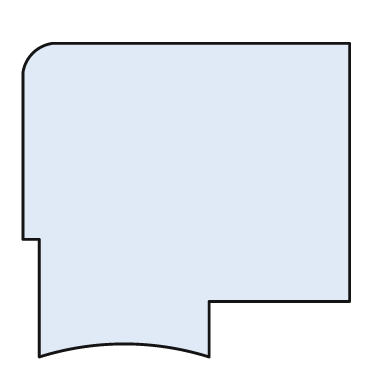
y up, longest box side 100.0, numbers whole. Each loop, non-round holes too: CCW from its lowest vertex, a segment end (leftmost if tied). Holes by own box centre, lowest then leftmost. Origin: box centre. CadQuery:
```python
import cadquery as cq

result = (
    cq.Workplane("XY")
    .moveTo(-45.0, -48.0)
    .threePointArc((-19.0, -44.0), (7.0, -48.0))
    .lineTo(7.0, -31.0)
    .lineTo(50.0, -31.0)
    .lineTo(50.0, 48.0)
    .lineTo(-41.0, 48.0)
    .threePointArc((-47.0, 45.0), (-50.0, 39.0))
    .lineTo(-50.0, -12.0)
    .lineTo(-45.0, -12.0)
    .close()
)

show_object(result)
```